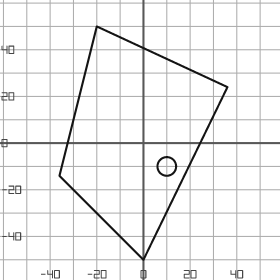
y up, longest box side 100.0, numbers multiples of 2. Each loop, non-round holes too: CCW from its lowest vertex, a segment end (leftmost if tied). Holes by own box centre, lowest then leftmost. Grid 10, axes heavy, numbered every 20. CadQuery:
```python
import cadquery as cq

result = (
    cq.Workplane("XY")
    .moveTo(0.0, -50.0)
    .lineTo(36.0, 24.0)
    .lineTo(-20.0, 50.0)
    .lineTo(-36.0, -14.0)
    .close()
    .moveTo(10.0, -10.0)
    .circle(4.0)
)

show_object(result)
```